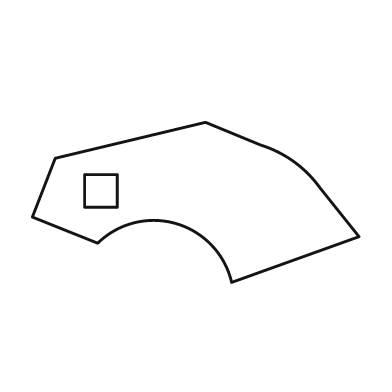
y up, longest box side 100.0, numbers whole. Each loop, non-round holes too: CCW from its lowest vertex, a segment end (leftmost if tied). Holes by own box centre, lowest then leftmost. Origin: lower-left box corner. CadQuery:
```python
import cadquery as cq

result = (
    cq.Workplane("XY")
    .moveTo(61.0, 0.0)
    .lineTo(100.0, 14.0)
    .lineTo(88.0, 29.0)
    .threePointArc((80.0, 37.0), (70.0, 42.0))
    .lineTo(53.0, 49.0)
    .lineTo(7.0, 38.0)
    .lineTo(0.0, 20.0)
    .lineTo(20.0, 12.0)
    .threePointArc((44.0, 18.0), (61.0, 0.0))
    .close()
    .moveTo(16.0, 23.0)
    .lineTo(26.0, 23.0)
    .lineTo(26.0, 33.0)
    .lineTo(16.0, 33.0)
    .close()
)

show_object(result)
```